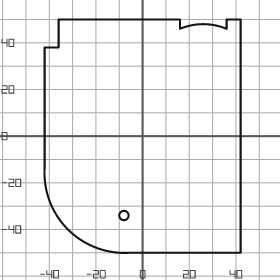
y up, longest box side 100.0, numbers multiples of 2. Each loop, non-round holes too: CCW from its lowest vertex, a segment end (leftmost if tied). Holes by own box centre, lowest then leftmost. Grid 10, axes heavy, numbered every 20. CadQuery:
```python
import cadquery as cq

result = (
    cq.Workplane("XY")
    .moveTo(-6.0, -50.0)
    .lineTo(42.0, -50.0)
    .lineTo(42.0, 50.0)
    .lineTo(36.0, 50.0)
    .lineTo(36.0, 46.0)
    .threePointArc((26.0, 48.0), (16.0, 46.0))
    .lineTo(16.0, 50.0)
    .lineTo(-36.0, 50.0)
    .lineTo(-36.0, 38.0)
    .lineTo(-42.0, 38.0)
    .lineTo(-42.0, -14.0)
    .threePointArc((-32.0, -40.0), (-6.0, -50.0))
    .close()
    .moveTo(-8.0, -34.0)
    .circle(2.0)
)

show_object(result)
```